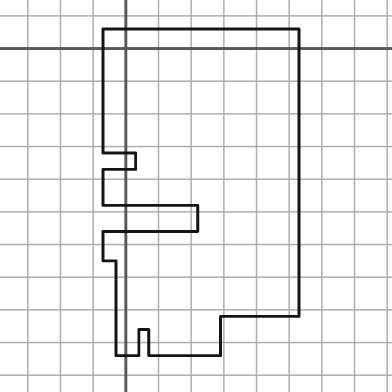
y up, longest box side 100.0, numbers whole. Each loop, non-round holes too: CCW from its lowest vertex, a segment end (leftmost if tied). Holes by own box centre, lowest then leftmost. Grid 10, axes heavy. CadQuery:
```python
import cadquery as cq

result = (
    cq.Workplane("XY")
    .moveTo(-3.0, -94.0)
    .lineTo(4.0, -94.0)
    .lineTo(4.0, -86.0)
    .lineTo(7.0, -86.0)
    .lineTo(7.0, -94.0)
    .lineTo(29.0, -94.0)
    .lineTo(29.0, -82.0)
    .lineTo(53.0, -82.0)
    .lineTo(53.0, 6.0)
    .lineTo(-7.0, 6.0)
    .lineTo(-7.0, -32.0)
    .lineTo(3.0, -32.0)
    .lineTo(3.0, -37.0)
    .lineTo(-7.0, -37.0)
    .lineTo(-7.0, -48.0)
    .lineTo(22.0, -48.0)
    .lineTo(22.0, -56.0)
    .lineTo(-7.0, -56.0)
    .lineTo(-7.0, -65.0)
    .lineTo(-3.0, -65.0)
    .close()
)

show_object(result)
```